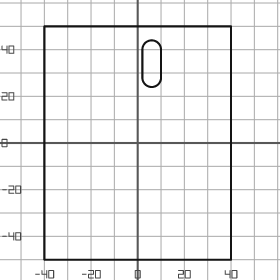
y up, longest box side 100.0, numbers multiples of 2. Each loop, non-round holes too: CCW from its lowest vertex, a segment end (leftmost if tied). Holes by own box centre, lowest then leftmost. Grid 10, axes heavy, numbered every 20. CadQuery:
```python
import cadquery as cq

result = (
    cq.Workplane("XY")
    .moveTo(-40.0, -50.0)
    .lineTo(40.0, -50.0)
    .lineTo(40.0, 50.0)
    .lineTo(-40.0, 50.0)
    .close()
    .moveTo(2.0, 28.0)
    .threePointArc((6.0, 24.0), (10.0, 28.0))
    .lineTo(10.0, 40.0)
    .threePointArc((6.0, 44.0), (2.0, 40.0))
    .close()
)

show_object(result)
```